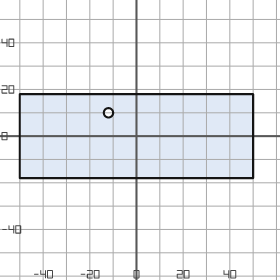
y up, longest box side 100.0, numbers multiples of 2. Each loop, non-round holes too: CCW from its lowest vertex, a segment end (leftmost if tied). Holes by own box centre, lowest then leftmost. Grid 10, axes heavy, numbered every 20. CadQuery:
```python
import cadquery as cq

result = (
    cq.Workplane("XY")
    .moveTo(-50.0, -18.0)
    .lineTo(50.0, -18.0)
    .lineTo(50.0, 18.0)
    .lineTo(-50.0, 18.0)
    .close()
    .moveTo(-12.0, 10.0)
    .circle(2.0)
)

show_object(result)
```